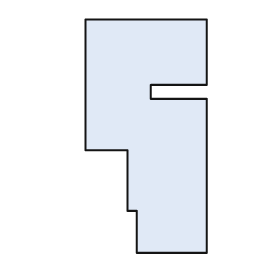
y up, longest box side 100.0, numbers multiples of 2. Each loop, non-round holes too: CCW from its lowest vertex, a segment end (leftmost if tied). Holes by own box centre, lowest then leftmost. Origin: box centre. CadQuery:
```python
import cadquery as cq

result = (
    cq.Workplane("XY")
    .moveTo(-4.0, -50.0)
    .lineTo(26.0, -50.0)
    .lineTo(26.0, 16.0)
    .lineTo(2.0, 16.0)
    .lineTo(2.0, 22.0)
    .lineTo(26.0, 22.0)
    .lineTo(26.0, 50.0)
    .lineTo(-26.0, 50.0)
    .lineTo(-26.0, -6.0)
    .lineTo(-8.0, -6.0)
    .lineTo(-8.0, -32.0)
    .lineTo(-4.0, -32.0)
    .close()
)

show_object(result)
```